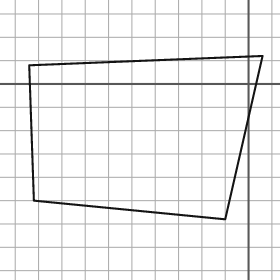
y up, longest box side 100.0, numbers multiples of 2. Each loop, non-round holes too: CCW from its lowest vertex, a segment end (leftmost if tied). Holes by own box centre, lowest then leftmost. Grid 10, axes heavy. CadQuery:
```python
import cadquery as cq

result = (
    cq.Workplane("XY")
    .moveTo(-10.0, -58.0)
    .lineTo(6.0, 12.0)
    .lineTo(-94.0, 8.0)
    .lineTo(-92.0, -50.0)
    .close()
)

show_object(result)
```